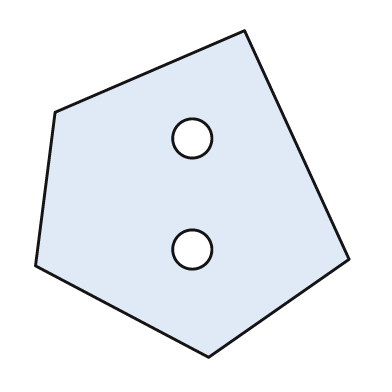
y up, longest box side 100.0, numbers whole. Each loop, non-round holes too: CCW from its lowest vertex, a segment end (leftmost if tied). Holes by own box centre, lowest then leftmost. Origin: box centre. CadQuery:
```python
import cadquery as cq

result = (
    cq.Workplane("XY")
    .moveTo(5.0, -50.0)
    .lineTo(48.0, -20.0)
    .lineTo(16.0, 50.0)
    .lineTo(-42.0, 25.0)
    .lineTo(-48.0, -22.0)
    .close()
    .moveTo(0.0, -17.0)
    .circle(6.0)
    .moveTo(0.0, 17.0)
    .circle(6.0)
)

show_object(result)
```